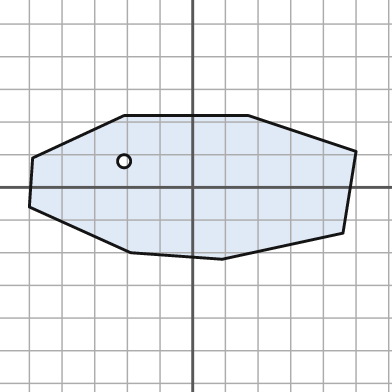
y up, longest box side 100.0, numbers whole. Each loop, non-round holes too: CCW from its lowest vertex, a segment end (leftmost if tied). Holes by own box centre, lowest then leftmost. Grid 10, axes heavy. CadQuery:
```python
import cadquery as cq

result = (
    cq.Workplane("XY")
    .moveTo(9.0, -22.0)
    .lineTo(46.0, -14.0)
    .lineTo(50.0, 11.0)
    .lineTo(17.0, 22.0)
    .lineTo(-21.0, 22.0)
    .lineTo(-49.0, 9.0)
    .lineTo(-50.0, -6.0)
    .lineTo(-19.0, -20.0)
    .close()
    .moveTo(-21.0, 8.0)
    .circle(2.0)
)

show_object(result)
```